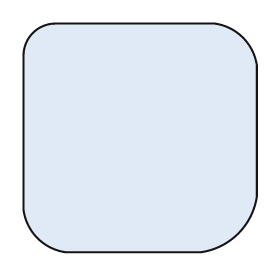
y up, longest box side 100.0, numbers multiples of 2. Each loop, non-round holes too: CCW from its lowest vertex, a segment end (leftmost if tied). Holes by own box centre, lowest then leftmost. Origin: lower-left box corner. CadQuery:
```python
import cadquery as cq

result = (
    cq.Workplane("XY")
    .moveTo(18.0, 0.0)
    .lineTo(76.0, 0.0)
    .threePointArc((92.0, 8.0), (100.0, 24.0))
    .lineTo(100.0, 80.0)
    .threePointArc((94.0, 92.0), (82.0, 98.0))
    .lineTo(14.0, 98.0)
    .threePointArc((4.0, 94.0), (0.0, 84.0))
    .lineTo(0.0, 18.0)
    .threePointArc((6.0, 6.0), (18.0, 0.0))
    .close()
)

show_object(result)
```